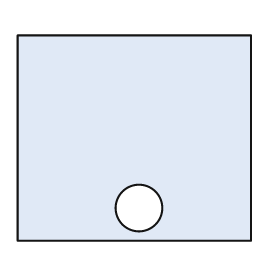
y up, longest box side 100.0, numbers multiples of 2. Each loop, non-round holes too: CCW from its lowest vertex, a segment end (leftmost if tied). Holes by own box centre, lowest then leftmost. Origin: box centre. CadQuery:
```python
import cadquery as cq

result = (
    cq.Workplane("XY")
    .moveTo(-50.0, -44.0)
    .lineTo(50.0, -44.0)
    .lineTo(50.0, 44.0)
    .lineTo(-50.0, 44.0)
    .close()
    .moveTo(2.0, -30.0)
    .circle(10.0)
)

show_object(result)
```